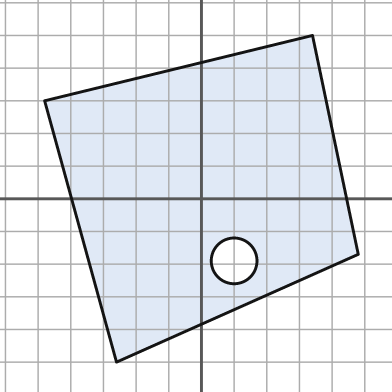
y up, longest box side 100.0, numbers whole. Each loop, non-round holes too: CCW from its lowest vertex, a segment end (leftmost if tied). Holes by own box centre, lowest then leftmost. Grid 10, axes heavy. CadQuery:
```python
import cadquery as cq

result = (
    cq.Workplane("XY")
    .moveTo(-26.0, -50.0)
    .lineTo(48.0, -17.0)
    .lineTo(34.0, 50.0)
    .lineTo(-48.0, 30.0)
    .close()
    .moveTo(10.0, -19.0)
    .circle(7.0)
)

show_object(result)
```